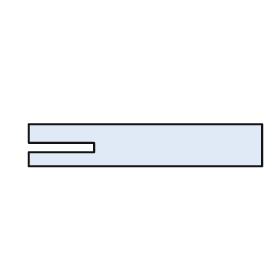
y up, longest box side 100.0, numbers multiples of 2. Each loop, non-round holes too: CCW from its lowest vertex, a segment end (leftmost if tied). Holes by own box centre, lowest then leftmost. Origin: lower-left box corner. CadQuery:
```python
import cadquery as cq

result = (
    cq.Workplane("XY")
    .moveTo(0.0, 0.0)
    .lineTo(100.0, 0.0)
    .lineTo(100.0, 18.0)
    .lineTo(0.0, 18.0)
    .lineTo(0.0, 10.0)
    .lineTo(28.0, 10.0)
    .lineTo(28.0, 6.0)
    .lineTo(0.0, 6.0)
    .close()
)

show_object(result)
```